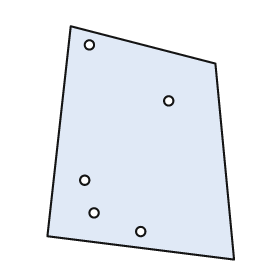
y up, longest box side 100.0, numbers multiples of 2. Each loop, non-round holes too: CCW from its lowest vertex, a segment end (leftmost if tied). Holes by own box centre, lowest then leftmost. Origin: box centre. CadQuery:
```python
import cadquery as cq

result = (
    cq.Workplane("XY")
    .moveTo(40.0, -50.0)
    .lineTo(32.0, 34.0)
    .lineTo(-30.0, 50.0)
    .lineTo(-40.0, -40.0)
    .close()
    .moveTo(0.0, -38.0)
    .circle(2.0)
    .moveTo(-20.0, -30.0)
    .circle(2.0)
    .moveTo(-24.0, -16.0)
    .circle(2.0)
    .moveTo(12.0, 18.0)
    .circle(2.0)
    .moveTo(-22.0, 42.0)
    .circle(2.0)
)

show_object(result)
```